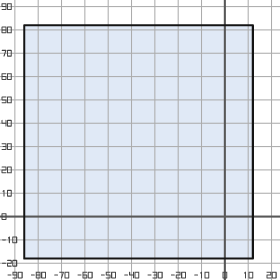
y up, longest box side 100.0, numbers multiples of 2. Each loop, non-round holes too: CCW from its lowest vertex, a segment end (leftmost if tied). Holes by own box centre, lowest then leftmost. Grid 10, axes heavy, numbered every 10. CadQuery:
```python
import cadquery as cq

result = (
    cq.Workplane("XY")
    .moveTo(-86.0, -18.0)
    .lineTo(12.0, -18.0)
    .lineTo(12.0, 82.0)
    .lineTo(-86.0, 82.0)
    .close()
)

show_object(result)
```